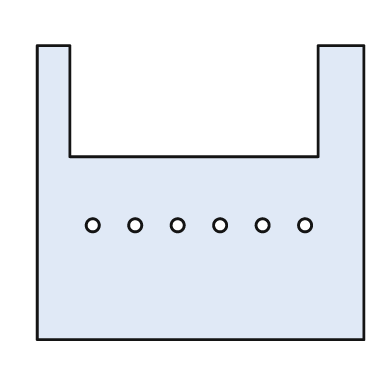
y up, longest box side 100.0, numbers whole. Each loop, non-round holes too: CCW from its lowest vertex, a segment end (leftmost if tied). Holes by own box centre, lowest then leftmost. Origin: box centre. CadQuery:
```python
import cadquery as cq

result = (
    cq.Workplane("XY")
    .moveTo(-50.0, -45.0)
    .lineTo(50.0, -45.0)
    .lineTo(50.0, 45.0)
    .lineTo(36.0, 45.0)
    .lineTo(36.0, 11.0)
    .lineTo(-40.0, 11.0)
    .lineTo(-40.0, 45.0)
    .lineTo(-50.0, 45.0)
    .close()
    .moveTo(-33.0, -10.0)
    .circle(2.0)
    .moveTo(-20.0, -10.0)
    .circle(2.0)
    .moveTo(-7.0, -10.0)
    .circle(2.0)
    .moveTo(6.0, -10.0)
    .circle(2.0)
    .moveTo(19.0, -10.0)
    .circle(2.0)
    .moveTo(32.0, -10.0)
    .circle(2.0)
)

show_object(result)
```